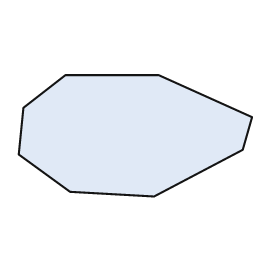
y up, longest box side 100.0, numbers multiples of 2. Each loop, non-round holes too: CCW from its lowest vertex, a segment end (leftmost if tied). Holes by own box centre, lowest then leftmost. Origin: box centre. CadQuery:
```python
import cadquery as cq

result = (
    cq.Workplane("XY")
    .moveTo(8.0, -26.0)
    .lineTo(46.0, -6.0)
    .lineTo(50.0, 8.0)
    .lineTo(10.0, 26.0)
    .lineTo(-30.0, 26.0)
    .lineTo(-48.0, 12.0)
    .lineTo(-50.0, -8.0)
    .lineTo(-28.0, -24.0)
    .close()
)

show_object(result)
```